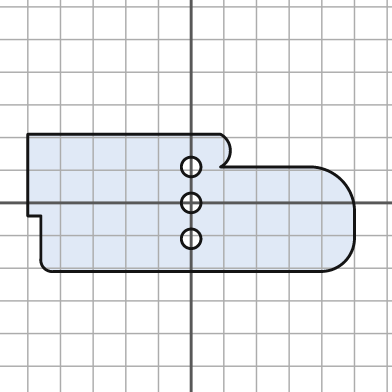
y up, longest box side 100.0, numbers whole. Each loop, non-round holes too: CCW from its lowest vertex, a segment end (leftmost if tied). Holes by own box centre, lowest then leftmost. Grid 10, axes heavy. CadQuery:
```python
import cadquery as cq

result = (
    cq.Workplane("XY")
    .moveTo(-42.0, -21.0)
    .lineTo(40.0, -21.0)
    .threePointArc((47.0, -18.0), (50.0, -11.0))
    .lineTo(50.0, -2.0)
    .threePointArc((46.0, 7.0), (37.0, 11.0))
    .lineTo(9.0, 11.0)
    .threePointArc((12.0, 16.0), (9.0, 21.0))
    .lineTo(-50.0, 21.0)
    .lineTo(-50.0, -4.0)
    .lineTo(-46.0, -4.0)
    .lineTo(-46.0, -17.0)
    .threePointArc((-45.0, -20.0), (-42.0, -21.0))
    .close()
    .moveTo(0.0, -11.0)
    .circle(3.0)
    .moveTo(0.0, 0.0)
    .circle(3.0)
    .moveTo(0.0, 11.0)
    .circle(3.0)
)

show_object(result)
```